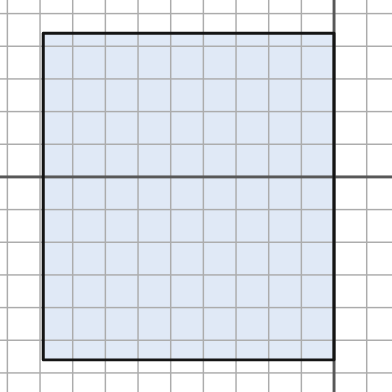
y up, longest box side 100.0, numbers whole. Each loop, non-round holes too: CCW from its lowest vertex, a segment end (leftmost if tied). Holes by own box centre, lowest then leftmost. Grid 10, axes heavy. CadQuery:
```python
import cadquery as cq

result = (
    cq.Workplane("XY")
    .moveTo(-89.0, -56.0)
    .lineTo(0.0, -56.0)
    .lineTo(0.0, 44.0)
    .lineTo(-89.0, 44.0)
    .close()
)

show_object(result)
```